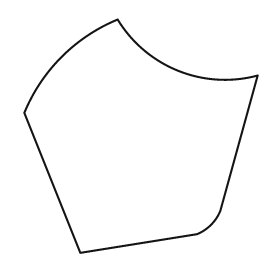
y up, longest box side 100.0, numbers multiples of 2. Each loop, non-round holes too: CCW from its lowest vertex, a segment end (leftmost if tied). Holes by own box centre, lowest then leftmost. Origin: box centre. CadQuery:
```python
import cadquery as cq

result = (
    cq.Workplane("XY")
    .moveTo(-26.0, -50.0)
    .lineTo(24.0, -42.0)
    .threePointArc((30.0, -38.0), (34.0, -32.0))
    .lineTo(50.0, 26.0)
    .threePointArc((16.0, 28.0), (-10.0, 50.0))
    .threePointArc((-34.0, 34.0), (-50.0, 10.0))
    .close()
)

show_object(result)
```